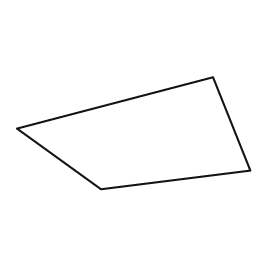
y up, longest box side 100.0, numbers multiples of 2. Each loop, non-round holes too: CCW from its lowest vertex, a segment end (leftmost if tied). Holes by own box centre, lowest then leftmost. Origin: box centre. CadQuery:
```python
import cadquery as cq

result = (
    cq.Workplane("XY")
    .moveTo(-14.0, -24.0)
    .lineTo(50.0, -16.0)
    .lineTo(34.0, 24.0)
    .lineTo(-50.0, 2.0)
    .close()
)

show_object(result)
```